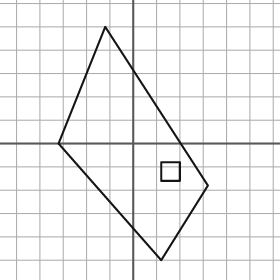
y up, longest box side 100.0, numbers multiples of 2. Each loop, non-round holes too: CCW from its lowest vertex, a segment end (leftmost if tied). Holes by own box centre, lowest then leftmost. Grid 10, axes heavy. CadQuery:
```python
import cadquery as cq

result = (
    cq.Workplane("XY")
    .moveTo(12.0, -50.0)
    .lineTo(32.0, -18.0)
    .lineTo(-12.0, 50.0)
    .lineTo(-32.0, 0.0)
    .close()
    .moveTo(12.0, -16.0)
    .lineTo(20.0, -16.0)
    .lineTo(20.0, -8.0)
    .lineTo(12.0, -8.0)
    .close()
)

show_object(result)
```